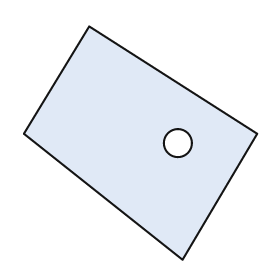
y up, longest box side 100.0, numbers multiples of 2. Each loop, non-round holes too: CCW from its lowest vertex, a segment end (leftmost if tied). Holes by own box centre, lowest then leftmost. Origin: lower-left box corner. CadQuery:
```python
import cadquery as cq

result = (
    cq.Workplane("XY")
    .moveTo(68.0, 0.0)
    .lineTo(100.0, 54.0)
    .lineTo(28.0, 100.0)
    .lineTo(0.0, 54.0)
    .close()
    .moveTo(66.0, 50.0)
    .circle(6.0)
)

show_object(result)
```